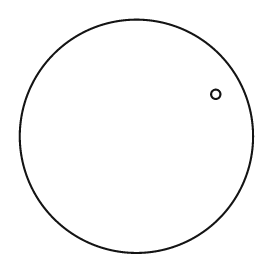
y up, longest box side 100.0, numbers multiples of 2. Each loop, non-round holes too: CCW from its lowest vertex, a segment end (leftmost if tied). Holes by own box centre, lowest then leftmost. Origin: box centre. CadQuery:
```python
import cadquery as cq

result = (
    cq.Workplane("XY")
    .moveTo(0.0, 0.0)
    .circle(50.0)
    .moveTo(34.0, 18.0)
    .circle(2.0)
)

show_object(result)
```